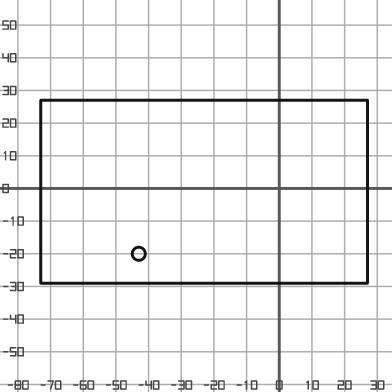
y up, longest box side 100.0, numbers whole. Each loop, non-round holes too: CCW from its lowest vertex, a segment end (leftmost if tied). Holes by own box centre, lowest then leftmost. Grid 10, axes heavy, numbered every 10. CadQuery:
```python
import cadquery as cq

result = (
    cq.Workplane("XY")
    .moveTo(-73.0, -29.0)
    .lineTo(27.0, -29.0)
    .lineTo(27.0, 27.0)
    .lineTo(-73.0, 27.0)
    .close()
    .moveTo(-43.0, -20.0)
    .circle(2.0)
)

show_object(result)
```